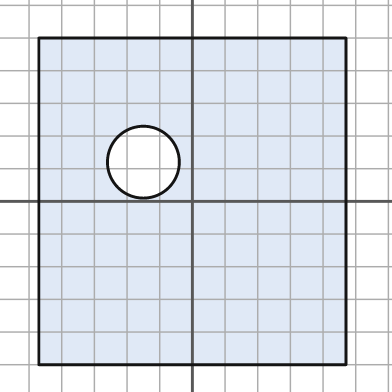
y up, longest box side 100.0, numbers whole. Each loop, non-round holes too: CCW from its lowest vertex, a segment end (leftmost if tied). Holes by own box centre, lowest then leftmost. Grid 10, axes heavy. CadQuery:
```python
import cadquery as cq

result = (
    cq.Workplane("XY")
    .moveTo(-47.0, -50.0)
    .lineTo(47.0, -50.0)
    .lineTo(47.0, 50.0)
    .lineTo(-47.0, 50.0)
    .close()
    .moveTo(-15.0, 12.0)
    .circle(11.0)
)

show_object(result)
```